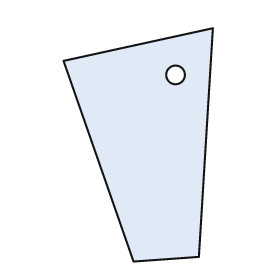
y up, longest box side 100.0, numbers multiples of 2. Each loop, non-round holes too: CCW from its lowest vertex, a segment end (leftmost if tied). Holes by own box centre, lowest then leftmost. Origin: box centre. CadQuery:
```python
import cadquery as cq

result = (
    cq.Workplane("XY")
    .moveTo(-2.0, -50.0)
    .lineTo(26.0, -48.0)
    .lineTo(32.0, 50.0)
    .lineTo(-32.0, 36.0)
    .close()
    .moveTo(16.0, 30.0)
    .circle(4.0)
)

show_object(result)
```